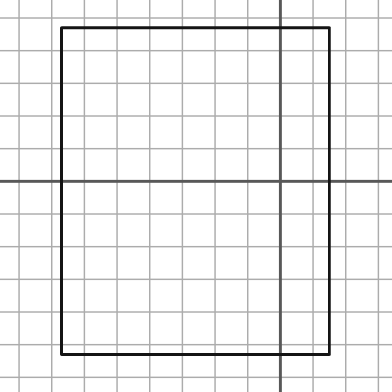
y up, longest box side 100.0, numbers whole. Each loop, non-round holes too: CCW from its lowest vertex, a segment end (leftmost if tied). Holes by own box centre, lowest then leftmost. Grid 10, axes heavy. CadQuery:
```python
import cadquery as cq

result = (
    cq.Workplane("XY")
    .moveTo(-67.0, -53.0)
    .lineTo(15.0, -53.0)
    .lineTo(15.0, 47.0)
    .lineTo(-67.0, 47.0)
    .close()
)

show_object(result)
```